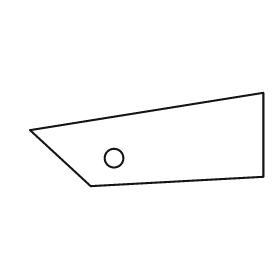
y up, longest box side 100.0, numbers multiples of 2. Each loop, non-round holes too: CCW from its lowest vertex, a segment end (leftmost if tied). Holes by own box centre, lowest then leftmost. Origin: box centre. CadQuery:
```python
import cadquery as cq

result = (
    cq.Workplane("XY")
    .moveTo(-24.0, -20.0)
    .lineTo(50.0, -16.0)
    .lineTo(50.0, 20.0)
    .lineTo(-50.0, 4.0)
    .close()
    .moveTo(-14.0, -8.0)
    .circle(4.0)
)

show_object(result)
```